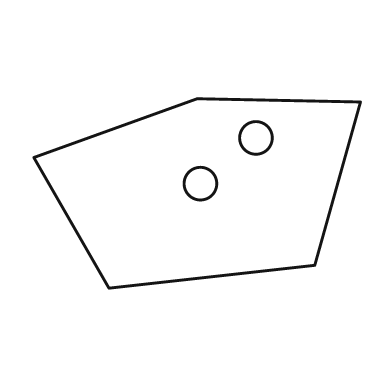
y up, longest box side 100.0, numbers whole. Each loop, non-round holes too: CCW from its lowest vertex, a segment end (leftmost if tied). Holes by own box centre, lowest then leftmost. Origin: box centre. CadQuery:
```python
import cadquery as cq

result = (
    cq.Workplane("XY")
    .moveTo(-27.0, -29.0)
    .lineTo(36.0, -22.0)
    .lineTo(50.0, 28.0)
    .lineTo(0.0, 29.0)
    .lineTo(-50.0, 11.0)
    .close()
    .moveTo(1.0, 3.0)
    .circle(5.0)
    .moveTo(18.0, 17.0)
    .circle(5.0)
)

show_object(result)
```